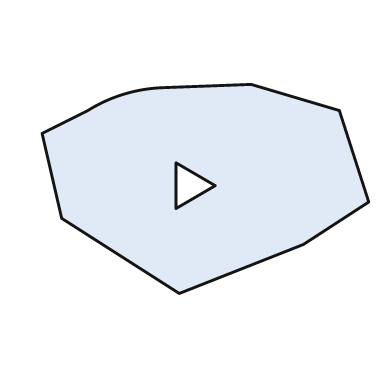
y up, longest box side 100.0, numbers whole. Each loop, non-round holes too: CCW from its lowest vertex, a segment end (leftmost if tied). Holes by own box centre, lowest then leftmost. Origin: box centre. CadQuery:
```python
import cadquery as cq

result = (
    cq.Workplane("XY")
    .moveTo(-8.0, -32.0)
    .lineTo(30.0, -17.0)
    .lineTo(50.0, -4.0)
    .lineTo(41.0, 24.0)
    .lineTo(14.0, 32.0)
    .lineTo(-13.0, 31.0)
    .threePointArc((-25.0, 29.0), (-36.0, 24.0))
    .lineTo(-50.0, 17.0)
    .lineTo(-44.0, -9.0)
    .close()
    .moveTo(-9.0, -6.0)
    .lineTo(3.0, 1.0)
    .lineTo(-9.0, 8.0)
    .close()
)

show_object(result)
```